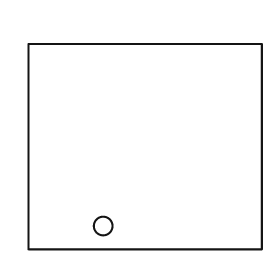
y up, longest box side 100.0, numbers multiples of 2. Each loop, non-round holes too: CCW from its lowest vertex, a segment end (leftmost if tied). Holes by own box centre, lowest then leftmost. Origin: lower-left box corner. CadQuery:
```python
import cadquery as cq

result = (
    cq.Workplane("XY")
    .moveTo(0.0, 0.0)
    .lineTo(100.0, 0.0)
    .lineTo(100.0, 88.0)
    .lineTo(0.0, 88.0)
    .close()
    .moveTo(32.0, 10.0)
    .circle(4.0)
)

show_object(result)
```